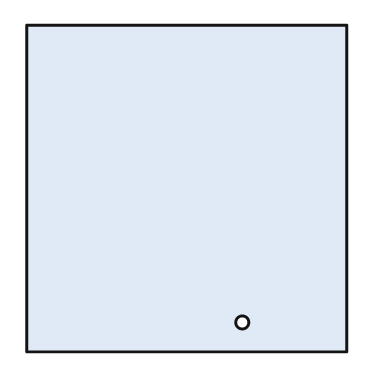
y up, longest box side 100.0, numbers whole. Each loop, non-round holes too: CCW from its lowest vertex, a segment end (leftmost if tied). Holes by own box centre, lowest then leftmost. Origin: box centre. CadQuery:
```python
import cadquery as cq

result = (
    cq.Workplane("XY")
    .moveTo(-49.0, -50.0)
    .lineTo(49.0, -50.0)
    .lineTo(49.0, 50.0)
    .lineTo(-49.0, 50.0)
    .close()
    .moveTo(17.0, -41.0)
    .circle(2.0)
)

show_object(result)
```